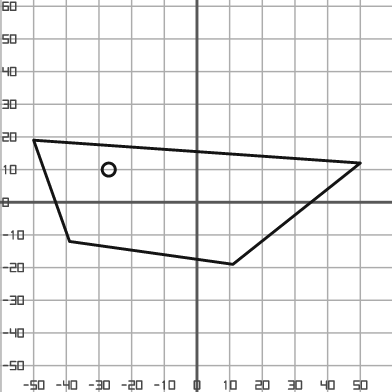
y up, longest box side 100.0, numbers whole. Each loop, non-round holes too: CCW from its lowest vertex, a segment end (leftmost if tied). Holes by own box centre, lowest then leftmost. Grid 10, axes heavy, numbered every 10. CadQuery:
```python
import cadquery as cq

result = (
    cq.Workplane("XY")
    .moveTo(11.0, -19.0)
    .lineTo(50.0, 12.0)
    .lineTo(-50.0, 19.0)
    .lineTo(-39.0, -12.0)
    .close()
    .moveTo(-27.0, 10.0)
    .circle(2.0)
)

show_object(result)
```